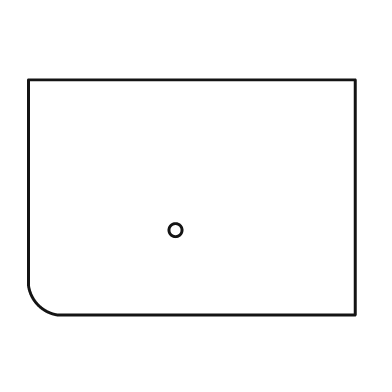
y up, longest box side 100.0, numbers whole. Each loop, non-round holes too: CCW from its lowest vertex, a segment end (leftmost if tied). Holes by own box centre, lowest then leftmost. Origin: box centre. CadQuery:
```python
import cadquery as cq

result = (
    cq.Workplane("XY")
    .moveTo(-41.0, -36.0)
    .lineTo(50.0, -36.0)
    .lineTo(50.0, 36.0)
    .lineTo(-50.0, 36.0)
    .lineTo(-50.0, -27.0)
    .threePointArc((-47.0, -33.0), (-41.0, -36.0))
    .close()
    .moveTo(-5.0, -10.0)
    .circle(2.0)
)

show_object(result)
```